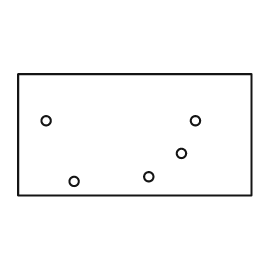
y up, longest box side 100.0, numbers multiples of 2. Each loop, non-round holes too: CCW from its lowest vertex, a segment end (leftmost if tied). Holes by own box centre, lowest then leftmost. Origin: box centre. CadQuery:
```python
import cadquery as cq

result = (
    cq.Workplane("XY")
    .moveTo(-50.0, -26.0)
    .lineTo(50.0, -26.0)
    .lineTo(50.0, 26.0)
    .lineTo(-50.0, 26.0)
    .close()
    .moveTo(-26.0, -20.0)
    .circle(2.0)
    .moveTo(6.0, -18.0)
    .circle(2.0)
    .moveTo(20.0, -8.0)
    .circle(2.0)
    .moveTo(-38.0, 6.0)
    .circle(2.0)
    .moveTo(26.0, 6.0)
    .circle(2.0)
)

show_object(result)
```